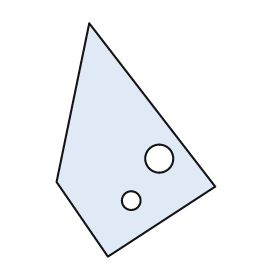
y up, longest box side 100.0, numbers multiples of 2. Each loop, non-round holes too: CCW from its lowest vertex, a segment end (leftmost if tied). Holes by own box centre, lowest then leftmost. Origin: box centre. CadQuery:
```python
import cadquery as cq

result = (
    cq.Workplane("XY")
    .moveTo(-12.0, -50.0)
    .lineTo(34.0, -20.0)
    .lineTo(-20.0, 50.0)
    .lineTo(-34.0, -18.0)
    .close()
    .moveTo(-2.0, -26.0)
    .circle(4.0)
    .moveTo(10.0, -8.0)
    .circle(6.0)
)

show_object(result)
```